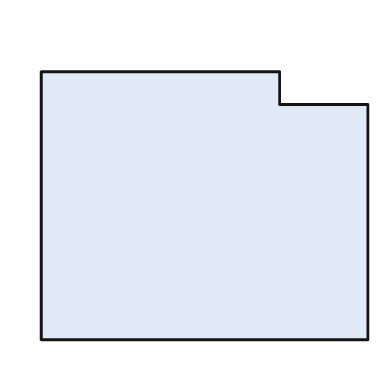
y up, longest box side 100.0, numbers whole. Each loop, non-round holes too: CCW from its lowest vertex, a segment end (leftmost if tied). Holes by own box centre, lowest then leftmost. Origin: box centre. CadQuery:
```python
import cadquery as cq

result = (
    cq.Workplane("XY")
    .moveTo(-50.0, -41.0)
    .lineTo(50.0, -41.0)
    .lineTo(50.0, 31.0)
    .lineTo(23.0, 31.0)
    .lineTo(23.0, 41.0)
    .lineTo(-50.0, 41.0)
    .close()
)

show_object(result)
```